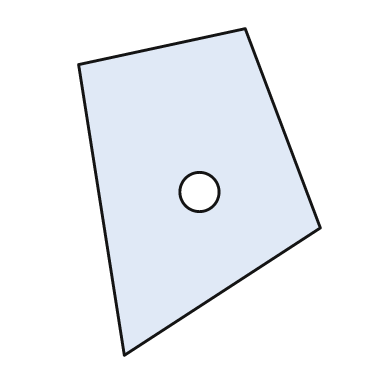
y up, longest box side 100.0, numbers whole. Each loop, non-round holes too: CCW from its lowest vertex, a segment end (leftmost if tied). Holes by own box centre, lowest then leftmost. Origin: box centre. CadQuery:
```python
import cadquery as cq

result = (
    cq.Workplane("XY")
    .moveTo(-23.0, -50.0)
    .lineTo(37.0, -11.0)
    .lineTo(14.0, 50.0)
    .lineTo(-37.0, 39.0)
    .close()
    .moveTo(0.0, 0.0)
    .circle(6.0)
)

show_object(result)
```